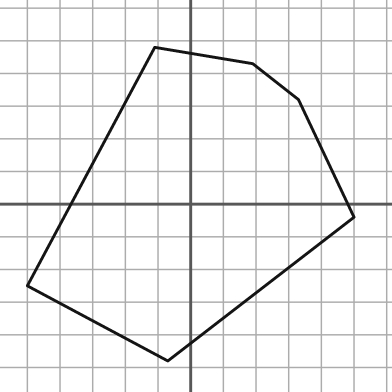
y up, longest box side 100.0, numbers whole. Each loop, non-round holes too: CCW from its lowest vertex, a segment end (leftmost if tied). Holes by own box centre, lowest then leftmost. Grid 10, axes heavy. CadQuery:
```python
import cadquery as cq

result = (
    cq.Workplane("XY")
    .moveTo(-7.0, -48.0)
    .lineTo(50.0, -4.0)
    .lineTo(33.0, 32.0)
    .lineTo(19.0, 43.0)
    .lineTo(-11.0, 48.0)
    .lineTo(-50.0, -25.0)
    .close()
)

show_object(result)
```